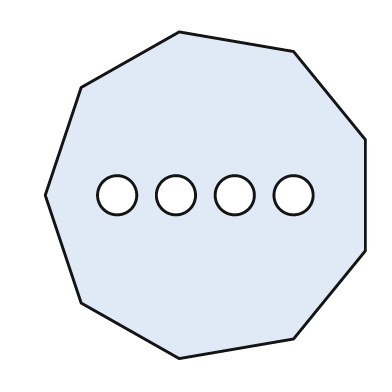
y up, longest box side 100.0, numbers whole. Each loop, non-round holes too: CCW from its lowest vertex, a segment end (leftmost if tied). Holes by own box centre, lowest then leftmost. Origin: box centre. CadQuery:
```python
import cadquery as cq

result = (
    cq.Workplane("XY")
    .moveTo(-8.0, -50.0)
    .lineTo(27.0, -44.0)
    .lineTo(49.0, -17.0)
    .lineTo(49.0, 17.0)
    .lineTo(27.0, 44.0)
    .lineTo(-8.0, 50.0)
    .lineTo(-38.0, 33.0)
    .lineTo(-49.0, 0.0)
    .lineTo(-38.0, -33.0)
    .close()
    .moveTo(-27.0, 0.0)
    .circle(6.0)
    .moveTo(-9.0, 0.0)
    .circle(6.0)
    .moveTo(9.0, 0.0)
    .circle(6.0)
    .moveTo(27.0, 0.0)
    .circle(6.0)
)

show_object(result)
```